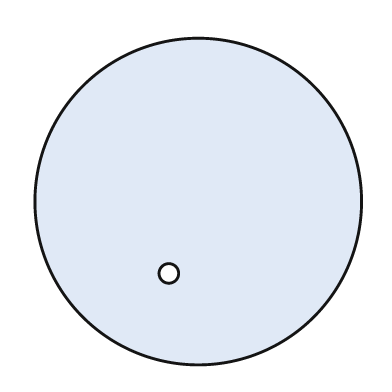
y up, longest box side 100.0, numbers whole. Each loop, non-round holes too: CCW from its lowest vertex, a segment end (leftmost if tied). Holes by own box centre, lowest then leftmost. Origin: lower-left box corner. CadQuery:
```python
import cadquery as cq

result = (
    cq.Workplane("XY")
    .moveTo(50.0, 50.0)
    .circle(50.0)
    .moveTo(41.0, 28.0)
    .circle(3.0)
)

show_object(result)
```